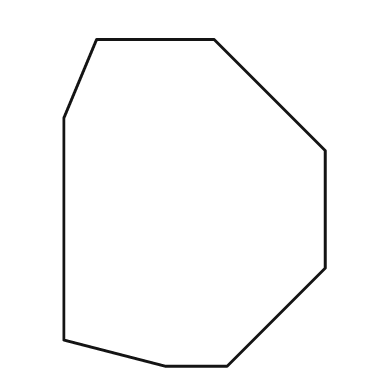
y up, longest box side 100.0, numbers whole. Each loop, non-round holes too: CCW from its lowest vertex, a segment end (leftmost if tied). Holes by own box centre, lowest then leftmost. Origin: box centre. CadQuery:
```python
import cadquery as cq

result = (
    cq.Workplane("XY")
    .moveTo(-9.0, -50.0)
    .lineTo(10.0, -50.0)
    .lineTo(40.0, -20.0)
    .lineTo(40.0, 16.0)
    .lineTo(6.0, 50.0)
    .lineTo(-30.0, 50.0)
    .lineTo(-40.0, 26.0)
    .lineTo(-40.0, -42.0)
    .close()
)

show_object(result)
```